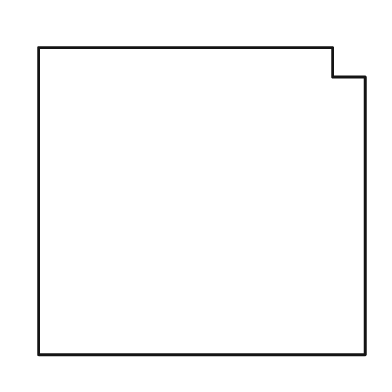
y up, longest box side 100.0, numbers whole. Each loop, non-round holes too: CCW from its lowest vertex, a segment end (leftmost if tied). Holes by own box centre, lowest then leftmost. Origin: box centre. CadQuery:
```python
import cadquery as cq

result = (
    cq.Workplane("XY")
    .moveTo(-50.0, -47.0)
    .lineTo(50.0, -47.0)
    .lineTo(50.0, 38.0)
    .lineTo(40.0, 38.0)
    .lineTo(40.0, 47.0)
    .lineTo(-50.0, 47.0)
    .close()
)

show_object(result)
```